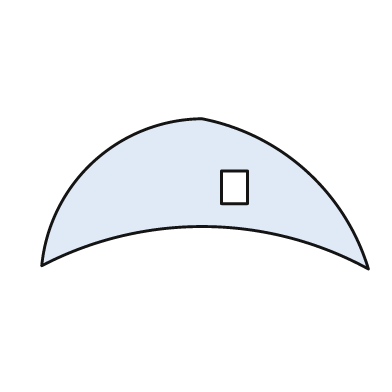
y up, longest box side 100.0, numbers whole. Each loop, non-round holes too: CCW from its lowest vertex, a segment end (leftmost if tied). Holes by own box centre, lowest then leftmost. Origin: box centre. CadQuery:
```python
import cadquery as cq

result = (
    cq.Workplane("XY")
    .moveTo(50.0, -23.0)
    .threePointArc((31.0, 7.0), (-1.0, 23.0))
    .threePointArc((-34.0, 10.0), (-50.0, -22.0))
    .threePointArc((0.0, -10.0), (50.0, -23.0))
    .close()
    .moveTo(5.0, -3.0)
    .lineTo(13.0, -3.0)
    .lineTo(13.0, 7.0)
    .lineTo(5.0, 7.0)
    .close()
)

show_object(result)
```